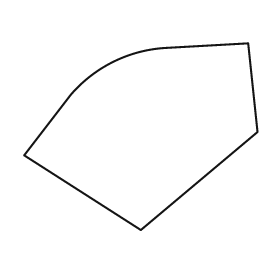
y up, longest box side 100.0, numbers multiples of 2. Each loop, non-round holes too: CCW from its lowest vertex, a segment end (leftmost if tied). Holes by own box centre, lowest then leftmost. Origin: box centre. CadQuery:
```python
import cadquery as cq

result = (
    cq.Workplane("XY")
    .moveTo(0.0, -40.0)
    .lineTo(50.0, 2.0)
    .lineTo(46.0, 40.0)
    .lineTo(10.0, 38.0)
    .threePointArc((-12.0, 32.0), (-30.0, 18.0))
    .lineTo(-50.0, -8.0)
    .close()
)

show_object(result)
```